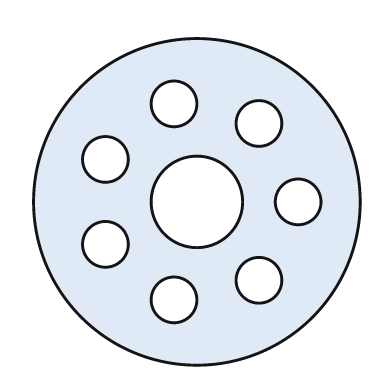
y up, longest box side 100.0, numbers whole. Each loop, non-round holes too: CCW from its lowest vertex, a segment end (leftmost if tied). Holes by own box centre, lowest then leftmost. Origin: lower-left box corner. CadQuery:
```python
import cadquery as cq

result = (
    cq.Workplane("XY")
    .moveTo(50.0, 50.0)
    .circle(50.0)
    .moveTo(43.0, 20.0)
    .circle(7.0)
    .moveTo(69.0, 26.0)
    .circle(7.0)
    .moveTo(22.0, 37.0)
    .circle(7.0)
    .moveTo(50.0, 50.0)
    .circle(14.0)
    .moveTo(81.0, 50.0)
    .circle(7.0)
    .moveTo(22.0, 63.0)
    .circle(7.0)
    .moveTo(69.0, 74.0)
    .circle(7.0)
    .moveTo(43.0, 80.0)
    .circle(7.0)
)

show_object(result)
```